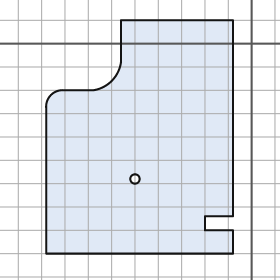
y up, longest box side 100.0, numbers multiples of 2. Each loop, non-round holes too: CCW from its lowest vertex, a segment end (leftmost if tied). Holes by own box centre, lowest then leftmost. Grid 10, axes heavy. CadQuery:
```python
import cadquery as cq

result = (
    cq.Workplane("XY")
    .moveTo(-88.0, -90.0)
    .lineTo(-8.0, -90.0)
    .lineTo(-8.0, -80.0)
    .lineTo(-20.0, -80.0)
    .lineTo(-20.0, -74.0)
    .lineTo(-8.0, -74.0)
    .lineTo(-8.0, 10.0)
    .lineTo(-56.0, 10.0)
    .lineTo(-56.0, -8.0)
    .threePointArc((-60.0, -16.0), (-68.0, -20.0))
    .lineTo(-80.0, -20.0)
    .threePointArc((-86.0, -22.0), (-88.0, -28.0))
    .close()
    .moveTo(-50.0, -58.0)
    .circle(2.0)
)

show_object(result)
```